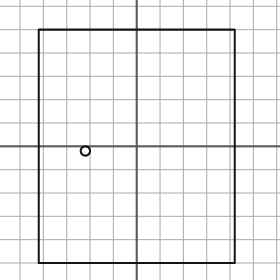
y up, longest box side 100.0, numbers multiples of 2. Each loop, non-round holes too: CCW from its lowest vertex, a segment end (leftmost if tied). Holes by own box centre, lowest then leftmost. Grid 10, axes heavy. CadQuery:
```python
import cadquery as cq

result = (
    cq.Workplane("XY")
    .moveTo(-42.0, -50.0)
    .lineTo(42.0, -50.0)
    .lineTo(42.0, 50.0)
    .lineTo(-42.0, 50.0)
    .close()
    .moveTo(-22.0, -2.0)
    .circle(2.0)
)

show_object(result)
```